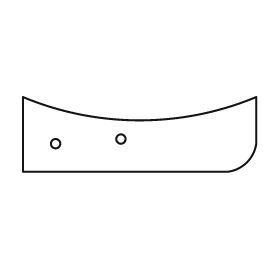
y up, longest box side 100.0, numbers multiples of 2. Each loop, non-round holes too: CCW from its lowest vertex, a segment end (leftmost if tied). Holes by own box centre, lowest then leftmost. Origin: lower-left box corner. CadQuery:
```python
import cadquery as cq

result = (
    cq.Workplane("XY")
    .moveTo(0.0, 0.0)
    .lineTo(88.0, 0.0)
    .threePointArc((96.0, 4.0), (100.0, 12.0))
    .lineTo(100.0, 32.0)
    .threePointArc((50.0, 22.0), (0.0, 32.0))
    .close()
    .moveTo(14.0, 12.0)
    .circle(2.0)
    .moveTo(42.0, 14.0)
    .circle(2.0)
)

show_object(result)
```